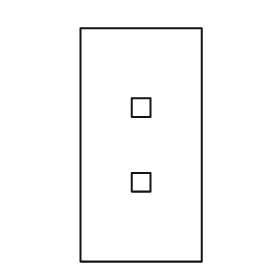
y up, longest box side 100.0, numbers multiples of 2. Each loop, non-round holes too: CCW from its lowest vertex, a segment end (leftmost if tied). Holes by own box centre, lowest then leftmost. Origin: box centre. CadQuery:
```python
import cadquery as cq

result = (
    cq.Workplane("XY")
    .moveTo(-26.0, -50.0)
    .lineTo(26.0, -50.0)
    .lineTo(26.0, 50.0)
    .lineTo(-26.0, 50.0)
    .close()
    .moveTo(-4.0, -20.0)
    .lineTo(4.0, -20.0)
    .lineTo(4.0, -12.0)
    .lineTo(-4.0, -12.0)
    .close()
    .moveTo(-4.0, 12.0)
    .lineTo(4.0, 12.0)
    .lineTo(4.0, 20.0)
    .lineTo(-4.0, 20.0)
    .close()
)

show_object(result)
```